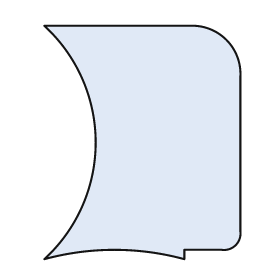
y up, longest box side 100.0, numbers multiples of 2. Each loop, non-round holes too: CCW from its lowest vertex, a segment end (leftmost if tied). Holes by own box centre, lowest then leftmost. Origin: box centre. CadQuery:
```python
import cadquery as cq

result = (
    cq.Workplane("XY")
    .moveTo(-42.0, -50.0)
    .threePointArc((-12.0, -46.0), (18.0, -50.0))
    .lineTo(18.0, -46.0)
    .lineTo(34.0, -46.0)
    .threePointArc((40.0, -44.0), (42.0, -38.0))
    .lineTo(42.0, 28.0)
    .threePointArc((36.0, 44.0), (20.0, 50.0))
    .lineTo(-42.0, 50.0)
    .threePointArc((-20.0, 0.0), (-42.0, -50.0))
    .close()
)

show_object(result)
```